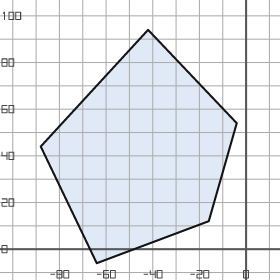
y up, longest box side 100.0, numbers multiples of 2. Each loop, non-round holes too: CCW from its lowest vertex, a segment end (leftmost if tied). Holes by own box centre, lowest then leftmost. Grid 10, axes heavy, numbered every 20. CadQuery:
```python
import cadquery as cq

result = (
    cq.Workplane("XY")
    .moveTo(-64.0, -6.0)
    .lineTo(-16.0, 12.0)
    .lineTo(-4.0, 54.0)
    .lineTo(-42.0, 94.0)
    .lineTo(-88.0, 44.0)
    .close()
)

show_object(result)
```